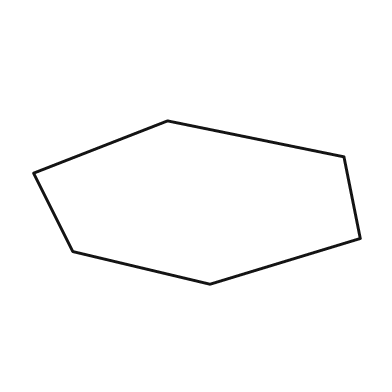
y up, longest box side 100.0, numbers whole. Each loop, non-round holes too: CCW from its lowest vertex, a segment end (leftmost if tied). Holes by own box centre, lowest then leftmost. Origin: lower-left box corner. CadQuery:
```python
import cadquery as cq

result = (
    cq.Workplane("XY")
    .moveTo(54.0, 0.0)
    .lineTo(100.0, 14.0)
    .lineTo(95.0, 39.0)
    .lineTo(41.0, 50.0)
    .lineTo(0.0, 34.0)
    .lineTo(12.0, 10.0)
    .close()
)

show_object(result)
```